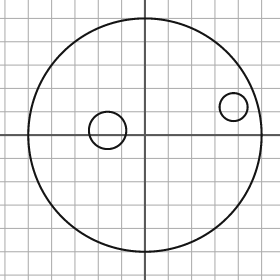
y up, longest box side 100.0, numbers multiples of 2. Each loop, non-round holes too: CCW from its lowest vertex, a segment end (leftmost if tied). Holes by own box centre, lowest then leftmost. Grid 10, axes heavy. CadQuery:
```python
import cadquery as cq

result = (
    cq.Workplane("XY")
    .moveTo(0.0, 0.0)
    .circle(50.0)
    .moveTo(-16.0, 2.0)
    .circle(8.0)
    .moveTo(38.0, 12.0)
    .circle(6.0)
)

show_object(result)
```